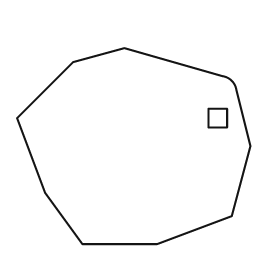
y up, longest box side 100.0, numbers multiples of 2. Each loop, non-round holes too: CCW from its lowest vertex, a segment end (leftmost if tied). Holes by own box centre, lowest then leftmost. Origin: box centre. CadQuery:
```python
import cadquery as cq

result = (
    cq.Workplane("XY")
    .moveTo(-22.0, -42.0)
    .lineTo(10.0, -42.0)
    .lineTo(42.0, -30.0)
    .lineTo(50.0, 0.0)
    .lineTo(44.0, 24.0)
    .threePointArc((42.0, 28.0), (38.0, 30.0))
    .lineTo(-4.0, 42.0)
    .lineTo(-26.0, 36.0)
    .lineTo(-50.0, 12.0)
    .lineTo(-38.0, -20.0)
    .close()
    .moveTo(32.0, 8.0)
    .lineTo(40.0, 8.0)
    .lineTo(40.0, 16.0)
    .lineTo(32.0, 16.0)
    .close()
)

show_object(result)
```